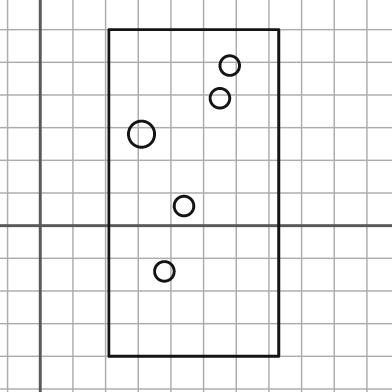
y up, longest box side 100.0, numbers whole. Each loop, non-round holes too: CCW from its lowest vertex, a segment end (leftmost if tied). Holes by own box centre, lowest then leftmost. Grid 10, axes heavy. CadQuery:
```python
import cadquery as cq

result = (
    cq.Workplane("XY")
    .moveTo(21.0, -40.0)
    .lineTo(73.0, -40.0)
    .lineTo(73.0, 60.0)
    .lineTo(21.0, 60.0)
    .close()
    .moveTo(38.0, -14.0)
    .circle(3.0)
    .moveTo(44.0, 6.0)
    .circle(3.0)
    .moveTo(31.0, 28.0)
    .circle(4.0)
    .moveTo(55.0, 39.0)
    .circle(3.0)
    .moveTo(58.0, 49.0)
    .circle(3.0)
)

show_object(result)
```